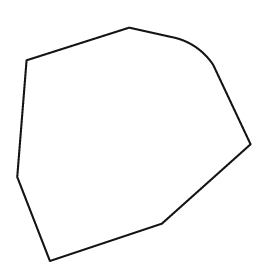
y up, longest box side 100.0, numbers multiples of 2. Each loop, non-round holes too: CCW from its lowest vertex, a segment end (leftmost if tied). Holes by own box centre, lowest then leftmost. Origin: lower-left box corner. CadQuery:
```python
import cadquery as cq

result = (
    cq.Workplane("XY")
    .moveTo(14.0, 0.0)
    .lineTo(62.0, 16.0)
    .lineTo(100.0, 50.0)
    .lineTo(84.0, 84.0)
    .threePointArc((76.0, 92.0), (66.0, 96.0))
    .lineTo(48.0, 100.0)
    .lineTo(4.0, 86.0)
    .lineTo(0.0, 36.0)
    .close()
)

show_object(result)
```